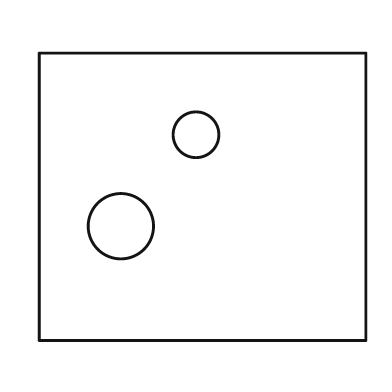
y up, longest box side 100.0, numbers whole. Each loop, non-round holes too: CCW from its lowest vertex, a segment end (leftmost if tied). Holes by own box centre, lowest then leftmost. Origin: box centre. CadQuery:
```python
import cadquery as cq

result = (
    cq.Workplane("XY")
    .moveTo(-50.0, -44.0)
    .lineTo(50.0, -44.0)
    .lineTo(50.0, 44.0)
    .lineTo(-50.0, 44.0)
    .close()
    .moveTo(-25.0, -9.0)
    .circle(10.0)
    .moveTo(-2.0, 19.0)
    .circle(7.0)
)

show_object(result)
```